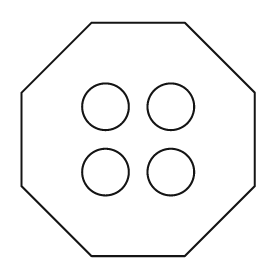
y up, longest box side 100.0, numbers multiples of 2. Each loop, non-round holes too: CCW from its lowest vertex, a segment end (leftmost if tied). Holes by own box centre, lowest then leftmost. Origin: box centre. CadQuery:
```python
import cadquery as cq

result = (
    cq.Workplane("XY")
    .moveTo(-20.0, -50.0)
    .lineTo(20.0, -50.0)
    .lineTo(50.0, -20.0)
    .lineTo(50.0, 20.0)
    .lineTo(20.0, 50.0)
    .lineTo(-20.0, 50.0)
    .lineTo(-50.0, 20.0)
    .lineTo(-50.0, -20.0)
    .close()
    .moveTo(-14.0, -14.0)
    .circle(10.0)
    .moveTo(14.0, -14.0)
    .circle(10.0)
    .moveTo(-14.0, 14.0)
    .circle(10.0)
    .moveTo(14.0, 14.0)
    .circle(10.0)
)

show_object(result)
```